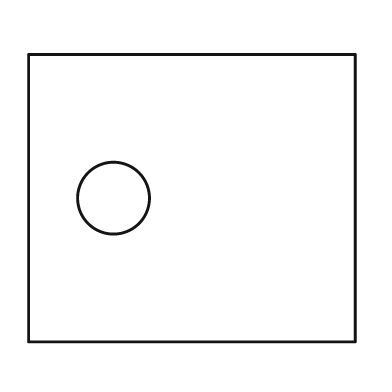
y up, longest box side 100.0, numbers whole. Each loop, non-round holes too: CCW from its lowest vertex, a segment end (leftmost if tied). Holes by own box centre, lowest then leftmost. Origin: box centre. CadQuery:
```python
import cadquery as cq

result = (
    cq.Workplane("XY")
    .moveTo(-50.0, -44.0)
    .lineTo(50.0, -44.0)
    .lineTo(50.0, 44.0)
    .lineTo(-50.0, 44.0)
    .close()
    .moveTo(-24.0, 0.0)
    .circle(11.0)
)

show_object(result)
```